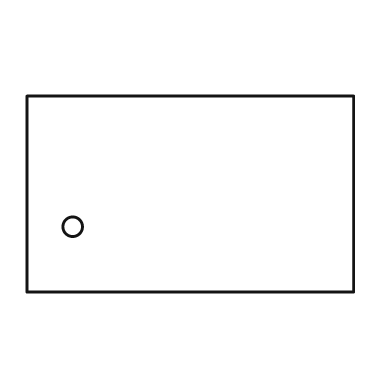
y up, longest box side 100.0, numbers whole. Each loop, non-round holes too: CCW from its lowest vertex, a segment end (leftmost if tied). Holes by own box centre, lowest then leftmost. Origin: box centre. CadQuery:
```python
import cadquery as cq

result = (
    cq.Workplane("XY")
    .moveTo(-50.0, -30.0)
    .lineTo(50.0, -30.0)
    .lineTo(50.0, 30.0)
    .lineTo(-50.0, 30.0)
    .close()
    .moveTo(-36.0, -10.0)
    .circle(3.0)
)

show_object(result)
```